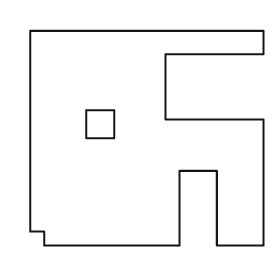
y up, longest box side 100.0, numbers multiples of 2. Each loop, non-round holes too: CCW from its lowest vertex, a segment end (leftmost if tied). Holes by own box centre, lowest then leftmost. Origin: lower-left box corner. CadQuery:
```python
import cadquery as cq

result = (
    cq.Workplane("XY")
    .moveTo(6.0, 0.0)
    .lineTo(64.0, 0.0)
    .lineTo(64.0, 32.0)
    .lineTo(80.0, 32.0)
    .lineTo(80.0, 0.0)
    .lineTo(100.0, 0.0)
    .lineTo(100.0, 54.0)
    .lineTo(58.0, 54.0)
    .lineTo(58.0, 82.0)
    .lineTo(100.0, 82.0)
    .lineTo(100.0, 92.0)
    .lineTo(0.0, 92.0)
    .lineTo(0.0, 6.0)
    .lineTo(6.0, 6.0)
    .close()
    .moveTo(24.0, 46.0)
    .lineTo(36.0, 46.0)
    .lineTo(36.0, 58.0)
    .lineTo(24.0, 58.0)
    .close()
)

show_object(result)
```